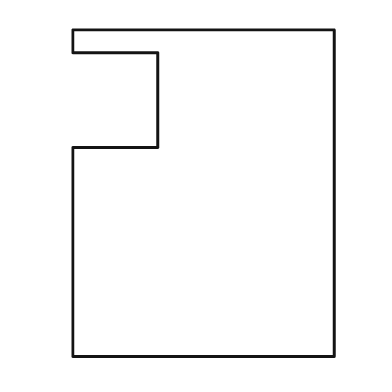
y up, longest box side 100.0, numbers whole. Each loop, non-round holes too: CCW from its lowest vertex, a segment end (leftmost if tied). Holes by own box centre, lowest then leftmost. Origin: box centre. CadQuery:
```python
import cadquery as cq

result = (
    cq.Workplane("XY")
    .moveTo(-40.0, -50.0)
    .lineTo(40.0, -50.0)
    .lineTo(40.0, 50.0)
    .lineTo(-40.0, 50.0)
    .lineTo(-40.0, 43.0)
    .lineTo(-14.0, 43.0)
    .lineTo(-14.0, 14.0)
    .lineTo(-40.0, 14.0)
    .close()
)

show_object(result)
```